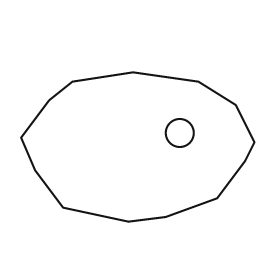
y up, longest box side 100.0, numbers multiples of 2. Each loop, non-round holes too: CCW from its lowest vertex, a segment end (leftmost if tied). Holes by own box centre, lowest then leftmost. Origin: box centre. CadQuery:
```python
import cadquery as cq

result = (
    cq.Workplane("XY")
    .moveTo(-4.0, -32.0)
    .lineTo(12.0, -30.0)
    .lineTo(34.0, -22.0)
    .lineTo(46.0, -6.0)
    .lineTo(50.0, 2.0)
    .lineTo(42.0, 18.0)
    .lineTo(26.0, 28.0)
    .lineTo(-2.0, 32.0)
    .lineTo(-28.0, 28.0)
    .lineTo(-38.0, 20.0)
    .lineTo(-50.0, 4.0)
    .lineTo(-44.0, -10.0)
    .lineTo(-32.0, -26.0)
    .close()
    .moveTo(18.0, 6.0)
    .circle(6.0)
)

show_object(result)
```